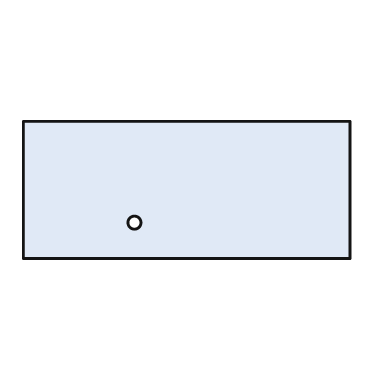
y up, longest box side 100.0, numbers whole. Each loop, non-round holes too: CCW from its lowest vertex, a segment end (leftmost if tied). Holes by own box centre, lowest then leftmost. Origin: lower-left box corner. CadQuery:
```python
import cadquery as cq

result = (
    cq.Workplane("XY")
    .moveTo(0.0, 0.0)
    .lineTo(100.0, 0.0)
    .lineTo(100.0, 42.0)
    .lineTo(0.0, 42.0)
    .close()
    .moveTo(34.0, 11.0)
    .circle(2.0)
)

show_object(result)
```